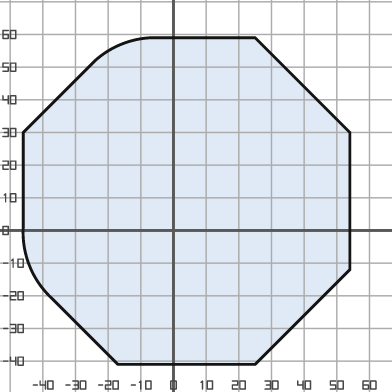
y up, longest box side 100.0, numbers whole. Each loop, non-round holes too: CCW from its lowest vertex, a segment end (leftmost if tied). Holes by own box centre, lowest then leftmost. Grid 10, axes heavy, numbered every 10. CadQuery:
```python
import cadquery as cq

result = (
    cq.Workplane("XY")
    .moveTo(-17.0, -41.0)
    .lineTo(25.0, -41.0)
    .lineTo(54.0, -12.0)
    .lineTo(54.0, 30.0)
    .lineTo(25.0, 59.0)
    .lineTo(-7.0, 59.0)
    .threePointArc((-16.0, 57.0), (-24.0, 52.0))
    .lineTo(-46.0, 30.0)
    .lineTo(-46.0, 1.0)
    .threePointArc((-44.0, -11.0), (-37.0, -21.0))
    .close()
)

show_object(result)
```